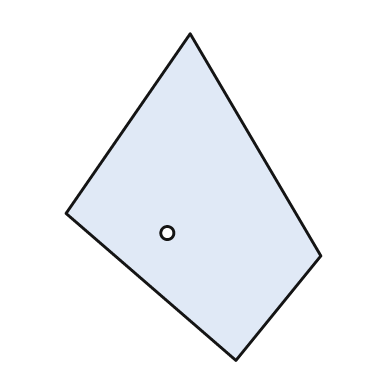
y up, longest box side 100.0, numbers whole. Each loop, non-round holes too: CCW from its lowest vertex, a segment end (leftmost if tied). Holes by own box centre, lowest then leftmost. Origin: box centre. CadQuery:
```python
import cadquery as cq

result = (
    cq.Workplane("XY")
    .moveTo(13.0, -50.0)
    .lineTo(39.0, -18.0)
    .lineTo(-1.0, 50.0)
    .lineTo(-39.0, -5.0)
    .close()
    .moveTo(-8.0, -11.0)
    .circle(2.0)
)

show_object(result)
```